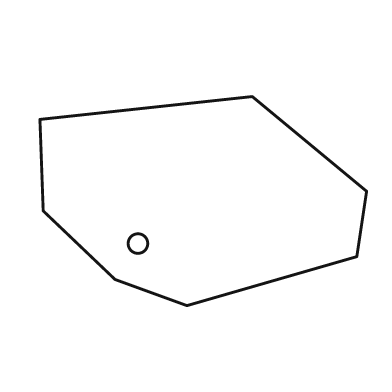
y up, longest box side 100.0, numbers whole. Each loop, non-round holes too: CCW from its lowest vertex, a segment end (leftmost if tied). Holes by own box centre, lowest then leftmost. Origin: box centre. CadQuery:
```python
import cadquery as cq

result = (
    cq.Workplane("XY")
    .moveTo(-5.0, -32.0)
    .lineTo(47.0, -17.0)
    .lineTo(50.0, 3.0)
    .lineTo(15.0, 32.0)
    .lineTo(-50.0, 25.0)
    .lineTo(-49.0, -3.0)
    .lineTo(-27.0, -24.0)
    .close()
    .moveTo(-20.0, -13.0)
    .circle(3.0)
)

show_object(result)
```